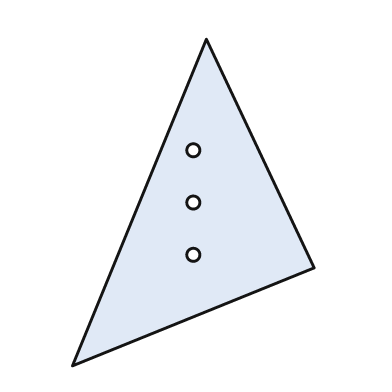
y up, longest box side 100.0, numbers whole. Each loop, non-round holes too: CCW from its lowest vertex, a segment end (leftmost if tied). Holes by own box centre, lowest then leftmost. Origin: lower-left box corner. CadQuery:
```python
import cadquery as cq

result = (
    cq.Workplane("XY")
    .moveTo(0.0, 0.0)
    .lineTo(74.0, 30.0)
    .lineTo(41.0, 100.0)
    .close()
    .moveTo(37.0, 34.0)
    .circle(2.0)
    .moveTo(37.0, 50.0)
    .circle(2.0)
    .moveTo(37.0, 66.0)
    .circle(2.0)
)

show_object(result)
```